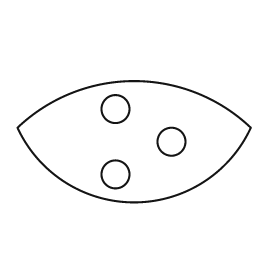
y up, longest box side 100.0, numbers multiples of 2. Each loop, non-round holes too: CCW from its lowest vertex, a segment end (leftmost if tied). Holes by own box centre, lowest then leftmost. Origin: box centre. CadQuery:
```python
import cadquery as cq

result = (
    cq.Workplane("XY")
    .moveTo(-50.0, 6.0)
    .threePointArc((0.0, -26.0), (50.0, 6.0))
    .threePointArc((0.0, 26.0), (-50.0, 6.0))
    .close()
    .moveTo(-8.0, -14.0)
    .circle(6.0)
    .moveTo(16.0, 0.0)
    .circle(6.0)
    .moveTo(-8.0, 14.0)
    .circle(6.0)
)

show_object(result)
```